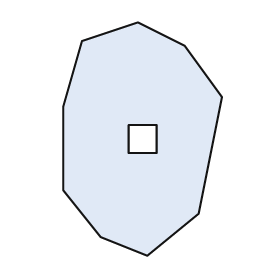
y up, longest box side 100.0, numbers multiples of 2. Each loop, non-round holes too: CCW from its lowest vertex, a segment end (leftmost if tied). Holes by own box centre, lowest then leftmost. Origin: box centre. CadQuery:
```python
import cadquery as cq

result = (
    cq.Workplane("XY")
    .moveTo(2.0, -50.0)
    .lineTo(24.0, -32.0)
    .lineTo(34.0, 18.0)
    .lineTo(18.0, 40.0)
    .lineTo(-2.0, 50.0)
    .lineTo(-26.0, 42.0)
    .lineTo(-34.0, 14.0)
    .lineTo(-34.0, -22.0)
    .lineTo(-18.0, -42.0)
    .close()
    .moveTo(-6.0, -6.0)
    .lineTo(6.0, -6.0)
    .lineTo(6.0, 6.0)
    .lineTo(-6.0, 6.0)
    .close()
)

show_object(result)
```